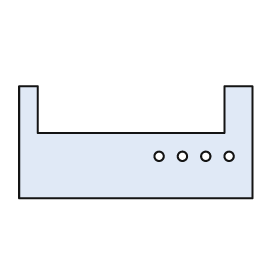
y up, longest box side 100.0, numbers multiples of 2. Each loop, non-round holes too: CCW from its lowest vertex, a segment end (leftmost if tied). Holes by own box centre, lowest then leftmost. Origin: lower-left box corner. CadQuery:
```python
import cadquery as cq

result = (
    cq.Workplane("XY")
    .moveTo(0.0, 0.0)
    .lineTo(100.0, 0.0)
    .lineTo(100.0, 48.0)
    .lineTo(88.0, 48.0)
    .lineTo(88.0, 28.0)
    .lineTo(8.0, 28.0)
    .lineTo(8.0, 48.0)
    .lineTo(0.0, 48.0)
    .close()
    .moveTo(60.0, 18.0)
    .circle(2.0)
    .moveTo(70.0, 18.0)
    .circle(2.0)
    .moveTo(80.0, 18.0)
    .circle(2.0)
    .moveTo(90.0, 18.0)
    .circle(2.0)
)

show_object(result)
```